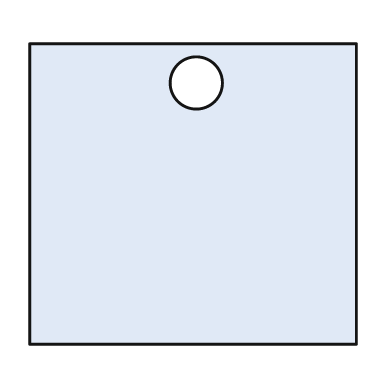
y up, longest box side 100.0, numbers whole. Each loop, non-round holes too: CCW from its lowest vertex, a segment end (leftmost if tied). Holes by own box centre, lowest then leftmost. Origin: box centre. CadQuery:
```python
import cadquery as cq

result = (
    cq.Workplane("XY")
    .moveTo(-50.0, -46.0)
    .lineTo(50.0, -46.0)
    .lineTo(50.0, 46.0)
    .lineTo(-50.0, 46.0)
    .close()
    .moveTo(1.0, 34.0)
    .circle(8.0)
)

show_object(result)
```